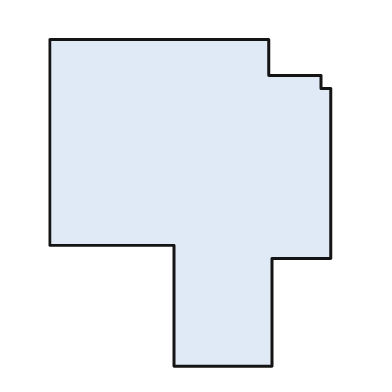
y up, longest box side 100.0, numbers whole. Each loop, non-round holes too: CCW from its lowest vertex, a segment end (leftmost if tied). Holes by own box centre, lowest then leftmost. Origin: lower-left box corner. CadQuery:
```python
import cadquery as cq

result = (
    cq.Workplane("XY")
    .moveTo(38.0, 0.0)
    .lineTo(68.0, 0.0)
    .lineTo(68.0, 33.0)
    .lineTo(86.0, 33.0)
    .lineTo(86.0, 85.0)
    .lineTo(83.0, 85.0)
    .lineTo(83.0, 89.0)
    .lineTo(67.0, 89.0)
    .lineTo(67.0, 100.0)
    .lineTo(0.0, 100.0)
    .lineTo(0.0, 37.0)
    .lineTo(38.0, 37.0)
    .close()
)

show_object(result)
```